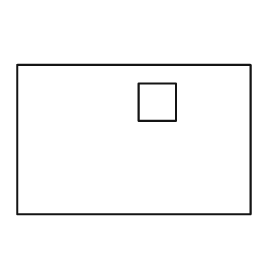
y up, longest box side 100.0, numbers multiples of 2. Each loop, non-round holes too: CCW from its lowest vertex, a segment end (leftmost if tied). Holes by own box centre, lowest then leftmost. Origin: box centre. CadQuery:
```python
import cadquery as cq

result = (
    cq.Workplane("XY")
    .moveTo(-50.0, -32.0)
    .lineTo(50.0, -32.0)
    .lineTo(50.0, 32.0)
    .lineTo(-50.0, 32.0)
    .close()
    .moveTo(2.0, 8.0)
    .lineTo(18.0, 8.0)
    .lineTo(18.0, 24.0)
    .lineTo(2.0, 24.0)
    .close()
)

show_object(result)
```